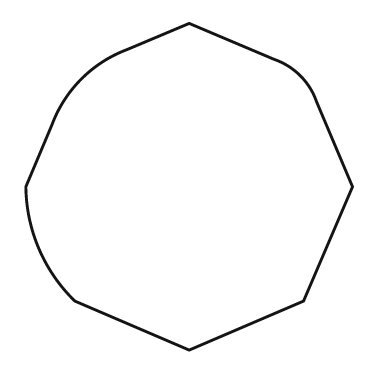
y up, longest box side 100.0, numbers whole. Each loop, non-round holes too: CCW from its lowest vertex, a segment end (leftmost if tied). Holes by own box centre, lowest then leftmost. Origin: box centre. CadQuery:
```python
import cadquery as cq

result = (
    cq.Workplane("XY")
    .moveTo(0.0, -50.0)
    .lineTo(35.0, -35.0)
    .lineTo(50.0, 0.0)
    .lineTo(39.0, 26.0)
    .threePointArc((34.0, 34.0), (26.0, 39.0))
    .lineTo(0.0, 50.0)
    .lineTo(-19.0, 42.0)
    .threePointArc((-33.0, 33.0), (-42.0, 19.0))
    .lineTo(-50.0, 0.0)
    .threePointArc((-46.0, -19.0), (-35.0, -35.0))
    .close()
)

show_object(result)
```